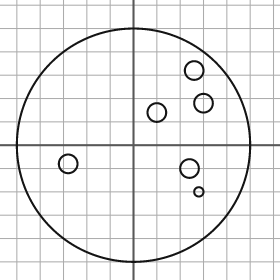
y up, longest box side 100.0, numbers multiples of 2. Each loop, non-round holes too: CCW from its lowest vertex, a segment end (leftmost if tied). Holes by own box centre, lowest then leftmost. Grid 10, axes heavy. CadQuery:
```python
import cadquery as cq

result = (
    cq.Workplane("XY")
    .moveTo(0.0, 0.0)
    .circle(50.0)
    .moveTo(28.0, -20.0)
    .circle(2.0)
    .moveTo(24.0, -10.0)
    .circle(4.0)
    .moveTo(-28.0, -8.0)
    .circle(4.0)
    .moveTo(10.0, 14.0)
    .circle(4.0)
    .moveTo(30.0, 18.0)
    .circle(4.0)
    .moveTo(26.0, 32.0)
    .circle(4.0)
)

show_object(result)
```